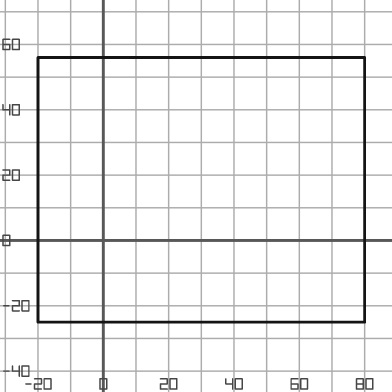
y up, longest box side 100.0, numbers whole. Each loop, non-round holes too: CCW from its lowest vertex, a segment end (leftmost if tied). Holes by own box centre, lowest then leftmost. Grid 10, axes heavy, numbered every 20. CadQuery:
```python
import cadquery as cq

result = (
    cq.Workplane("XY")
    .moveTo(-20.0, -25.0)
    .lineTo(80.0, -25.0)
    .lineTo(80.0, 56.0)
    .lineTo(-20.0, 56.0)
    .close()
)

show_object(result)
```